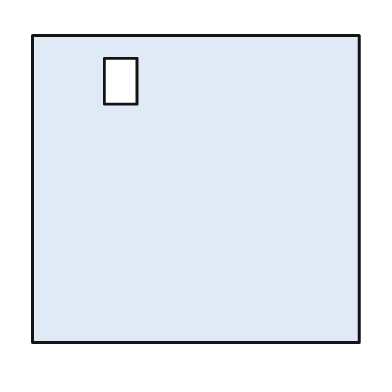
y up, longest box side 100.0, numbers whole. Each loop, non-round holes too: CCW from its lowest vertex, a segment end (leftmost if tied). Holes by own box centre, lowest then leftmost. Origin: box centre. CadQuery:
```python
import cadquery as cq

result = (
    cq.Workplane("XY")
    .moveTo(-50.0, -47.0)
    .lineTo(50.0, -47.0)
    .lineTo(50.0, 47.0)
    .lineTo(-50.0, 47.0)
    .close()
    .moveTo(-28.0, 26.0)
    .lineTo(-18.0, 26.0)
    .lineTo(-18.0, 40.0)
    .lineTo(-28.0, 40.0)
    .close()
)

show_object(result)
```